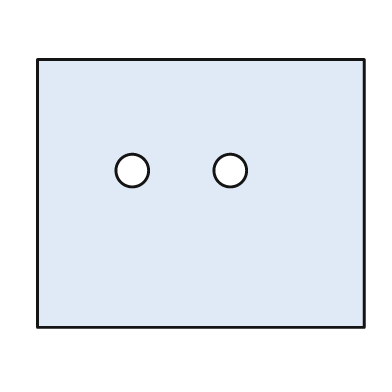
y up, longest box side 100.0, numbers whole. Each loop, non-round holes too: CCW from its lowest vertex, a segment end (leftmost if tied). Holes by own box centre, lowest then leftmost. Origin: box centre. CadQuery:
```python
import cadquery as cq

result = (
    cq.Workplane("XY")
    .moveTo(-50.0, -41.0)
    .lineTo(50.0, -41.0)
    .lineTo(50.0, 41.0)
    .lineTo(-50.0, 41.0)
    .close()
    .moveTo(-21.0, 7.0)
    .circle(5.0)
    .moveTo(9.0, 7.0)
    .circle(5.0)
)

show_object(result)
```